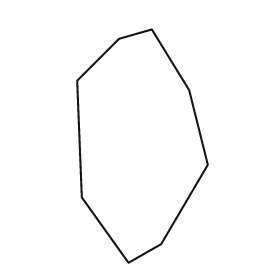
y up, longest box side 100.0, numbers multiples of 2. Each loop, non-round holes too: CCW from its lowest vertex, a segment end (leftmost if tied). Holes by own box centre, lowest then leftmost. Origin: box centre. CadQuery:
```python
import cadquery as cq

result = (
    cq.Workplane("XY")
    .moveTo(-6.0, -50.0)
    .lineTo(8.0, -42.0)
    .lineTo(28.0, -8.0)
    .lineTo(20.0, 24.0)
    .lineTo(4.0, 50.0)
    .lineTo(-10.0, 46.0)
    .lineTo(-28.0, 28.0)
    .lineTo(-26.0, -22.0)
    .close()
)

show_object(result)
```